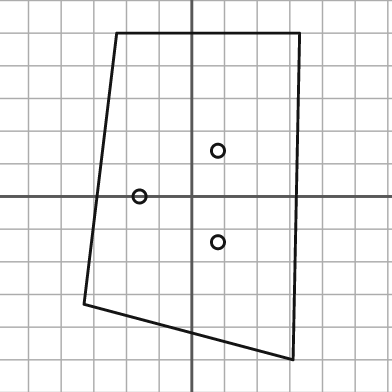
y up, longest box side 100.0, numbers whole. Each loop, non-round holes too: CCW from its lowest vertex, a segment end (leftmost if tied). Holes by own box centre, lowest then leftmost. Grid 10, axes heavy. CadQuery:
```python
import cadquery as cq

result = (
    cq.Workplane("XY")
    .moveTo(31.0, -50.0)
    .lineTo(33.0, 50.0)
    .lineTo(-23.0, 50.0)
    .lineTo(-33.0, -33.0)
    .close()
    .moveTo(8.0, -14.0)
    .circle(2.0)
    .moveTo(-16.0, 0.0)
    .circle(2.0)
    .moveTo(8.0, 14.0)
    .circle(2.0)
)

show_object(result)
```